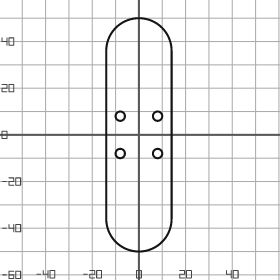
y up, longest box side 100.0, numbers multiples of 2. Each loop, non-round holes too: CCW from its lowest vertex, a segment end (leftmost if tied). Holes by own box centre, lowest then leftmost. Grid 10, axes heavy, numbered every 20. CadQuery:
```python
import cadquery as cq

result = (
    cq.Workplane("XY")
    .moveTo(-14.0, -36.0)
    .threePointArc((0.0, -50.0), (14.0, -36.0))
    .lineTo(14.0, 36.0)
    .threePointArc((0.0, 50.0), (-14.0, 36.0))
    .close()
    .moveTo(-8.0, -8.0)
    .circle(2.0)
    .moveTo(8.0, -8.0)
    .circle(2.0)
    .moveTo(-8.0, 8.0)
    .circle(2.0)
    .moveTo(8.0, 8.0)
    .circle(2.0)
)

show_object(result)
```